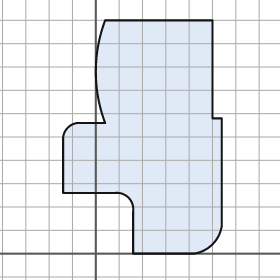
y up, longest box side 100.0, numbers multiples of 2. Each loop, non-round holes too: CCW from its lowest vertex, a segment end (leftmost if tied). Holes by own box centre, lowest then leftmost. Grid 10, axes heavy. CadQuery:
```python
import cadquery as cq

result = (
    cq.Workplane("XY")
    .moveTo(16.0, 0.0)
    .lineTo(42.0, 0.0)
    .threePointArc((50.0, 4.0), (54.0, 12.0))
    .lineTo(54.0, 58.0)
    .lineTo(50.0, 58.0)
    .lineTo(50.0, 100.0)
    .lineTo(4.0, 100.0)
    .threePointArc((0.0, 78.0), (4.0, 56.0))
    .lineTo(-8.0, 56.0)
    .threePointArc((-12.0, 54.0), (-14.0, 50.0))
    .lineTo(-14.0, 26.0)
    .lineTo(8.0, 26.0)
    .threePointArc((14.0, 24.0), (16.0, 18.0))
    .close()
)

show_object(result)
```